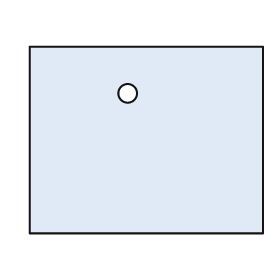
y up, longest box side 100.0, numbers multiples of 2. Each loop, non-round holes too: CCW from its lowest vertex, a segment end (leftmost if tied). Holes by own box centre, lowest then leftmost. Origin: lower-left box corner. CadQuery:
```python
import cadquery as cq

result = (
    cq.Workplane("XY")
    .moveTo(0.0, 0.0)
    .lineTo(100.0, 0.0)
    .lineTo(100.0, 80.0)
    .lineTo(0.0, 80.0)
    .close()
    .moveTo(42.0, 60.0)
    .circle(4.0)
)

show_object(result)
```